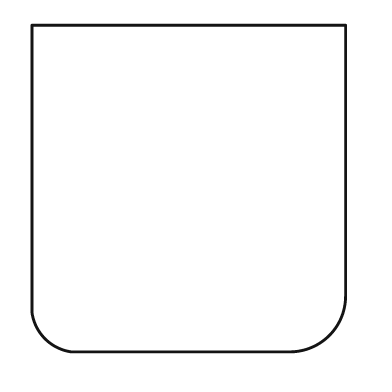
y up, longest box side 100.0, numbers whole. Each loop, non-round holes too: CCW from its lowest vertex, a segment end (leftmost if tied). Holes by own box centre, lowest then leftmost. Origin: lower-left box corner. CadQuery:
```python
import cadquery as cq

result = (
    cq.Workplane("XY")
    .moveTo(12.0, 0.0)
    .lineTo(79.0, 0.0)
    .threePointArc((91.0, 5.0), (96.0, 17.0))
    .lineTo(96.0, 100.0)
    .lineTo(0.0, 100.0)
    .lineTo(0.0, 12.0)
    .threePointArc((4.0, 4.0), (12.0, 0.0))
    .close()
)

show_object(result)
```